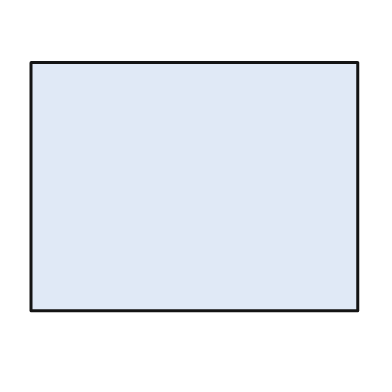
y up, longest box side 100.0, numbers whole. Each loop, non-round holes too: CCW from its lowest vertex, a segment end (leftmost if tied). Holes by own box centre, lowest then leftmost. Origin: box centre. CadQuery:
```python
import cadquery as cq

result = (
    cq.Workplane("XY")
    .moveTo(-50.0, -38.0)
    .lineTo(50.0, -38.0)
    .lineTo(50.0, 38.0)
    .lineTo(-50.0, 38.0)
    .close()
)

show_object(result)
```